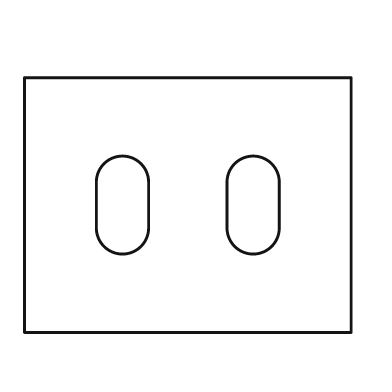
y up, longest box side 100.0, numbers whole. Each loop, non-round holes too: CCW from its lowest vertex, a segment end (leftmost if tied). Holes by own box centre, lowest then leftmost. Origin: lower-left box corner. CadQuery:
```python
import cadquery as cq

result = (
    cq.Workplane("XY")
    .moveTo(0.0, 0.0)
    .lineTo(100.0, 0.0)
    .lineTo(100.0, 78.0)
    .lineTo(0.0, 78.0)
    .close()
    .moveTo(22.0, 32.0)
    .threePointArc((30.0, 24.0), (38.0, 32.0))
    .lineTo(38.0, 46.0)
    .threePointArc((30.0, 54.0), (22.0, 46.0))
    .close()
    .moveTo(62.0, 32.0)
    .threePointArc((70.0, 24.0), (78.0, 32.0))
    .lineTo(78.0, 46.0)
    .threePointArc((70.0, 54.0), (62.0, 46.0))
    .close()
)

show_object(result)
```